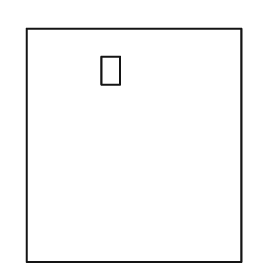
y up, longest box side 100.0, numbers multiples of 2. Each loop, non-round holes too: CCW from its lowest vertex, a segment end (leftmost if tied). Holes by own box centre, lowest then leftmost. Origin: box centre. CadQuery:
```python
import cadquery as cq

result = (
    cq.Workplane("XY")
    .moveTo(-46.0, -50.0)
    .lineTo(46.0, -50.0)
    .lineTo(46.0, 50.0)
    .lineTo(-46.0, 50.0)
    .close()
    .moveTo(-14.0, 26.0)
    .lineTo(-6.0, 26.0)
    .lineTo(-6.0, 38.0)
    .lineTo(-14.0, 38.0)
    .close()
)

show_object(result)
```